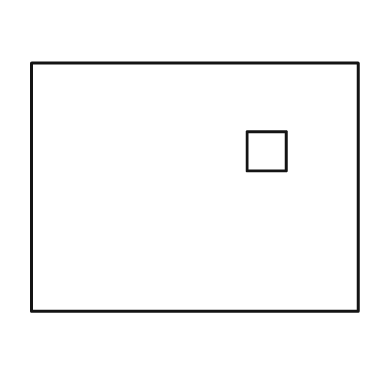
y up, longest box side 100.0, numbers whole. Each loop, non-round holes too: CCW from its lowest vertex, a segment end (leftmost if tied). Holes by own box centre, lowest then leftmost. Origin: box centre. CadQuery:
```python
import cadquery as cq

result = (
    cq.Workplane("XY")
    .moveTo(-50.0, -38.0)
    .lineTo(50.0, -38.0)
    .lineTo(50.0, 38.0)
    .lineTo(-50.0, 38.0)
    .close()
    .moveTo(16.0, 5.0)
    .lineTo(28.0, 5.0)
    .lineTo(28.0, 17.0)
    .lineTo(16.0, 17.0)
    .close()
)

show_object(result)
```